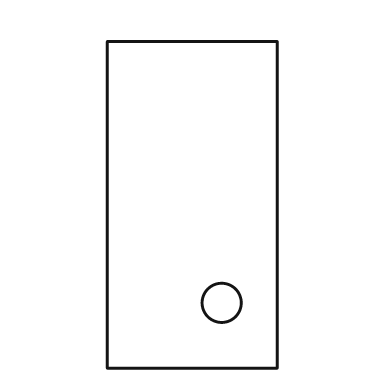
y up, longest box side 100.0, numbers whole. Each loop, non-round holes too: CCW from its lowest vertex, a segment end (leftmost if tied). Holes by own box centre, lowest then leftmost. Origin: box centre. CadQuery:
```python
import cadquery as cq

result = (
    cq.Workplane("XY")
    .moveTo(-26.0, -50.0)
    .lineTo(26.0, -50.0)
    .lineTo(26.0, 50.0)
    .lineTo(-26.0, 50.0)
    .close()
    .moveTo(9.0, -30.0)
    .circle(6.0)
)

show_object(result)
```